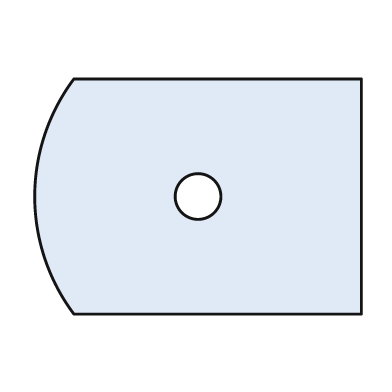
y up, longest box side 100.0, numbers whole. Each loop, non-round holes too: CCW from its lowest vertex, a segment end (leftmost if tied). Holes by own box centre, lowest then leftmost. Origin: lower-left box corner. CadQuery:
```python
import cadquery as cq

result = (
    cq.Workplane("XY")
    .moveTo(12.0, 0.0)
    .lineTo(100.0, 0.0)
    .lineTo(100.0, 72.0)
    .lineTo(12.0, 72.0)
    .threePointArc((0.0, 36.0), (12.0, 0.0))
    .close()
    .moveTo(50.0, 36.0)
    .circle(7.0)
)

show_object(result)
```